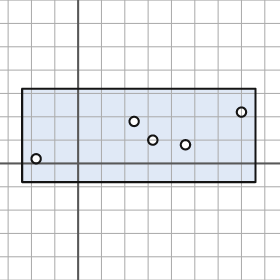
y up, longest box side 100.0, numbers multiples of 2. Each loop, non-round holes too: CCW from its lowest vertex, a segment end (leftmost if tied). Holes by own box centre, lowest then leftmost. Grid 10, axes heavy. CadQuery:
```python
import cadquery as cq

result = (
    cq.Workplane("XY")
    .moveTo(-24.0, -8.0)
    .lineTo(76.0, -8.0)
    .lineTo(76.0, 32.0)
    .lineTo(-24.0, 32.0)
    .close()
    .moveTo(-18.0, 2.0)
    .circle(2.0)
    .moveTo(46.0, 8.0)
    .circle(2.0)
    .moveTo(32.0, 10.0)
    .circle(2.0)
    .moveTo(24.0, 18.0)
    .circle(2.0)
    .moveTo(70.0, 22.0)
    .circle(2.0)
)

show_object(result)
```